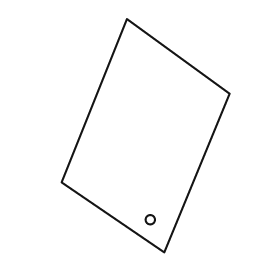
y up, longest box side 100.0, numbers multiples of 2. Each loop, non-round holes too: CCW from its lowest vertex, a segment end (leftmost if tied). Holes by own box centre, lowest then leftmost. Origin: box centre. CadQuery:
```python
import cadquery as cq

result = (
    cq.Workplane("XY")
    .moveTo(8.0, -50.0)
    .lineTo(36.0, 18.0)
    .lineTo(-8.0, 50.0)
    .lineTo(-36.0, -20.0)
    .close()
    .moveTo(2.0, -36.0)
    .circle(2.0)
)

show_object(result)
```